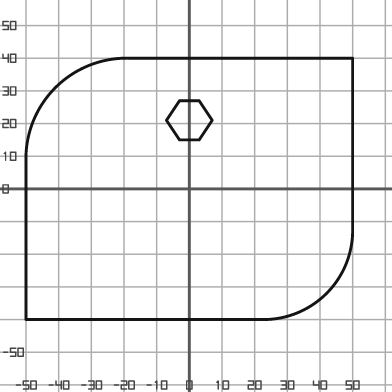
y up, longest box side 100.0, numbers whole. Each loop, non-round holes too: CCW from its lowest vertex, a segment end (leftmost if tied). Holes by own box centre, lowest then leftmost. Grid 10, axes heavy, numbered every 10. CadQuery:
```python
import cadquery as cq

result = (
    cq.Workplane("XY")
    .moveTo(-50.0, -40.0)
    .lineTo(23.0, -40.0)
    .threePointArc((42.0, -32.0), (50.0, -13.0))
    .lineTo(50.0, 40.0)
    .lineTo(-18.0, 40.0)
    .threePointArc((-41.0, 31.0), (-50.0, 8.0))
    .close()
    .moveTo(-3.0, 15.0)
    .lineTo(3.0, 15.0)
    .lineTo(7.0, 21.0)
    .lineTo(3.0, 27.0)
    .lineTo(-3.0, 27.0)
    .lineTo(-7.0, 21.0)
    .close()
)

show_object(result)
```